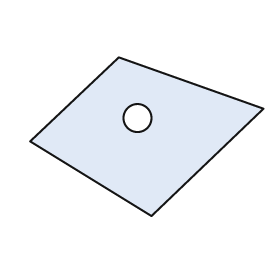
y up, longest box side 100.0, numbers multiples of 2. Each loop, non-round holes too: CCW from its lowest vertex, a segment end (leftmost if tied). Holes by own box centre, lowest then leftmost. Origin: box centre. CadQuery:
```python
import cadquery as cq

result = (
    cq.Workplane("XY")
    .moveTo(2.0, -34.0)
    .lineTo(50.0, 12.0)
    .lineTo(-12.0, 34.0)
    .lineTo(-50.0, -2.0)
    .close()
    .moveTo(-4.0, 8.0)
    .circle(6.0)
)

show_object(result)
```